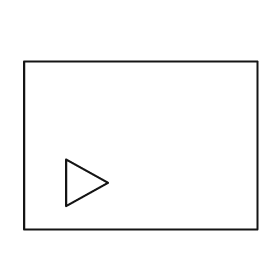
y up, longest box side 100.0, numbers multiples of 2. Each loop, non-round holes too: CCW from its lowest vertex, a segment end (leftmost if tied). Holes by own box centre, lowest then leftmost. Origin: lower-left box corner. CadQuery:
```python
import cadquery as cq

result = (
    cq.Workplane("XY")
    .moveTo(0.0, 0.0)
    .lineTo(100.0, 0.0)
    .lineTo(100.0, 72.0)
    .lineTo(0.0, 72.0)
    .close()
    .moveTo(18.0, 10.0)
    .lineTo(36.0, 20.0)
    .lineTo(18.0, 30.0)
    .close()
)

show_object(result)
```